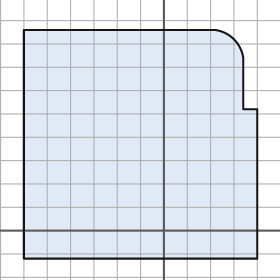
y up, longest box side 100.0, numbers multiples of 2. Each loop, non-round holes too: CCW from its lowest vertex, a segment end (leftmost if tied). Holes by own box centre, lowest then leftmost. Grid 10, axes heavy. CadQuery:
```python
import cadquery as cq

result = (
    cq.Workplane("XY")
    .moveTo(-60.0, -12.0)
    .lineTo(40.0, -12.0)
    .lineTo(40.0, 52.0)
    .lineTo(34.0, 52.0)
    .lineTo(34.0, 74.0)
    .threePointArc((30.0, 82.0), (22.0, 86.0))
    .lineTo(-60.0, 86.0)
    .close()
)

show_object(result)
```